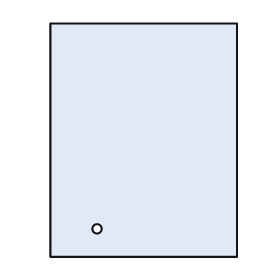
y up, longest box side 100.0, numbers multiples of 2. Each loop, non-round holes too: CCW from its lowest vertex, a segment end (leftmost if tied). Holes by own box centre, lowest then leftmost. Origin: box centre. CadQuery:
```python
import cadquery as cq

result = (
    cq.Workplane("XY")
    .moveTo(-40.0, -50.0)
    .lineTo(40.0, -50.0)
    .lineTo(40.0, 50.0)
    .lineTo(-40.0, 50.0)
    .close()
    .moveTo(-20.0, -38.0)
    .circle(2.0)
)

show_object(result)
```